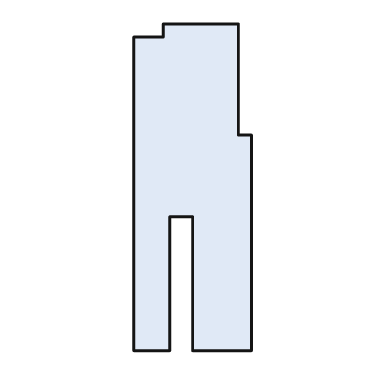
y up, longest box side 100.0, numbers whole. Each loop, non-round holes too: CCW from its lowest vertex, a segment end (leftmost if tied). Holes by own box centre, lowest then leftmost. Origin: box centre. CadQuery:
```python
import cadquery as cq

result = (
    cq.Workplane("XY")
    .moveTo(-18.0, -50.0)
    .lineTo(-7.0, -50.0)
    .lineTo(-7.0, -9.0)
    .lineTo(0.0, -9.0)
    .lineTo(0.0, -50.0)
    .lineTo(18.0, -50.0)
    .lineTo(18.0, 16.0)
    .lineTo(14.0, 16.0)
    .lineTo(14.0, 50.0)
    .lineTo(-9.0, 50.0)
    .lineTo(-9.0, 46.0)
    .lineTo(-18.0, 46.0)
    .close()
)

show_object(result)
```